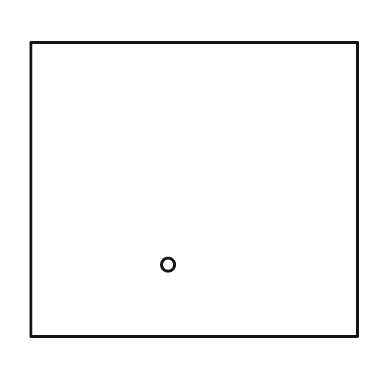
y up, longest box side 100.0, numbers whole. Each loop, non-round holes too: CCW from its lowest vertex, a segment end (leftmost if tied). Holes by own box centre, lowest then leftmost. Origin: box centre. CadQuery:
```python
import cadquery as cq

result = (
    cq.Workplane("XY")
    .moveTo(-50.0, -45.0)
    .lineTo(50.0, -45.0)
    .lineTo(50.0, 45.0)
    .lineTo(-50.0, 45.0)
    .close()
    .moveTo(-8.0, -23.0)
    .circle(2.0)
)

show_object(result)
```